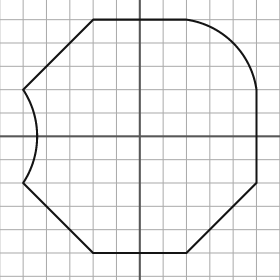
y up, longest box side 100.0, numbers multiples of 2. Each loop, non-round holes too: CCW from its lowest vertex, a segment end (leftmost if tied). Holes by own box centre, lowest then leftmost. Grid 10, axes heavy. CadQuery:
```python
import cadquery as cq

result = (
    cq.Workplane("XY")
    .moveTo(-20.0, -50.0)
    .lineTo(20.0, -50.0)
    .lineTo(50.0, -20.0)
    .lineTo(50.0, 20.0)
    .threePointArc((40.0, 40.0), (20.0, 50.0))
    .lineTo(-20.0, 50.0)
    .lineTo(-50.0, 20.0)
    .threePointArc((-44.0, 0.0), (-50.0, -20.0))
    .close()
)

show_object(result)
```